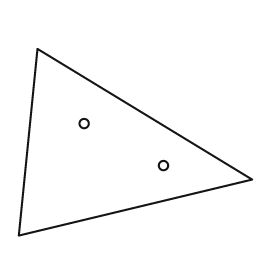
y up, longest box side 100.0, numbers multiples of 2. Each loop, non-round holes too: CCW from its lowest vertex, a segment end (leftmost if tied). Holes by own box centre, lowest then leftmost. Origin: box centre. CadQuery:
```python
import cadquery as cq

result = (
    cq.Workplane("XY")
    .moveTo(-50.0, -40.0)
    .lineTo(50.0, -16.0)
    .lineTo(-42.0, 40.0)
    .close()
    .moveTo(12.0, -10.0)
    .circle(2.0)
    .moveTo(-22.0, 8.0)
    .circle(2.0)
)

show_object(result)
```